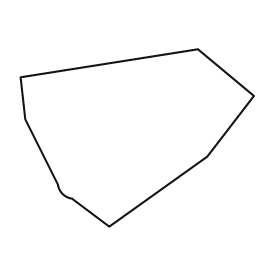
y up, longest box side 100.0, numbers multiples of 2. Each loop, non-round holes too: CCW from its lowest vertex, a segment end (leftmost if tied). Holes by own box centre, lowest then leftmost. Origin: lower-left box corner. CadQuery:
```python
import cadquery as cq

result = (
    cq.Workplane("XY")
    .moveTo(38.0, 0.0)
    .lineTo(80.0, 30.0)
    .lineTo(100.0, 56.0)
    .lineTo(76.0, 76.0)
    .lineTo(0.0, 64.0)
    .lineTo(2.0, 46.0)
    .lineTo(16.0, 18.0)
    .threePointArc((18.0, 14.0), (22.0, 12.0))
    .close()
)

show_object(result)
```